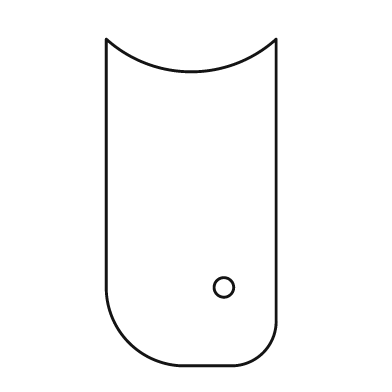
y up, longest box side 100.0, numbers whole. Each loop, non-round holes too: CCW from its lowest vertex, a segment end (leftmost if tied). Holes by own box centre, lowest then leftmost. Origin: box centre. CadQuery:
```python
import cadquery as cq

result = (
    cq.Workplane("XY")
    .moveTo(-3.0, -50.0)
    .lineTo(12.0, -50.0)
    .threePointArc((22.0, -46.0), (26.0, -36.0))
    .lineTo(26.0, 50.0)
    .threePointArc((0.0, 40.0), (-26.0, 50.0))
    .lineTo(-26.0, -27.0)
    .threePointArc((-19.0, -43.0), (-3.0, -50.0))
    .close()
    .moveTo(10.0, -26.0)
    .circle(3.0)
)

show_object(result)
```